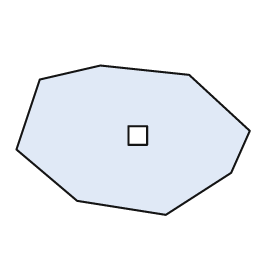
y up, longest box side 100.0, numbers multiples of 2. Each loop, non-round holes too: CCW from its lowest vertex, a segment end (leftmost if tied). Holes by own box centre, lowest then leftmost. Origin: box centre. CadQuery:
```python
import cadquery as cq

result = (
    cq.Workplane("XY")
    .moveTo(14.0, -32.0)
    .lineTo(42.0, -14.0)
    .lineTo(50.0, 4.0)
    .lineTo(24.0, 28.0)
    .lineTo(-14.0, 32.0)
    .lineTo(-40.0, 26.0)
    .lineTo(-50.0, -4.0)
    .lineTo(-24.0, -26.0)
    .close()
    .moveTo(-2.0, -2.0)
    .lineTo(6.0, -2.0)
    .lineTo(6.0, 6.0)
    .lineTo(-2.0, 6.0)
    .close()
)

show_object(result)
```